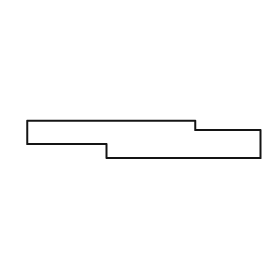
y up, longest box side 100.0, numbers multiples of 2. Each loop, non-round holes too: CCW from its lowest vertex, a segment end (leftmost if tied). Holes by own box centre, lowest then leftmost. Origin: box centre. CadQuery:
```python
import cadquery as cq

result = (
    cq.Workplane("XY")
    .moveTo(-16.0, -8.0)
    .lineTo(50.0, -8.0)
    .lineTo(50.0, 4.0)
    .lineTo(22.0, 4.0)
    .lineTo(22.0, 8.0)
    .lineTo(-50.0, 8.0)
    .lineTo(-50.0, -2.0)
    .lineTo(-16.0, -2.0)
    .close()
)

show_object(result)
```